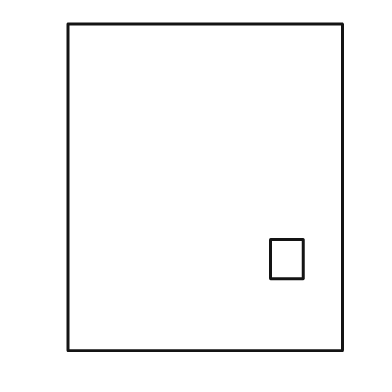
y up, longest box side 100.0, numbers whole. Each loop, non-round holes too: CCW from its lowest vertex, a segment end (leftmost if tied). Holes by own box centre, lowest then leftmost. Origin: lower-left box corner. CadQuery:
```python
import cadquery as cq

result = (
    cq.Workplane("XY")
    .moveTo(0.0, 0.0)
    .lineTo(84.0, 0.0)
    .lineTo(84.0, 100.0)
    .lineTo(0.0, 100.0)
    .close()
    .moveTo(62.0, 22.0)
    .lineTo(72.0, 22.0)
    .lineTo(72.0, 34.0)
    .lineTo(62.0, 34.0)
    .close()
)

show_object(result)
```